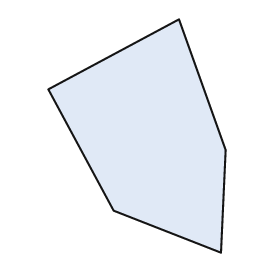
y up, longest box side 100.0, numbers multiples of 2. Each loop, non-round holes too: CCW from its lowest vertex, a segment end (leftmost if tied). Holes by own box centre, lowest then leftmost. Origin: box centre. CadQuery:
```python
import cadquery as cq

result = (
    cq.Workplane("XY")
    .moveTo(36.0, -50.0)
    .lineTo(38.0, -6.0)
    .lineTo(18.0, 50.0)
    .lineTo(-38.0, 20.0)
    .lineTo(-10.0, -32.0)
    .close()
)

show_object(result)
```